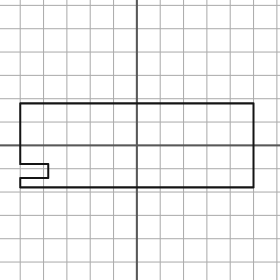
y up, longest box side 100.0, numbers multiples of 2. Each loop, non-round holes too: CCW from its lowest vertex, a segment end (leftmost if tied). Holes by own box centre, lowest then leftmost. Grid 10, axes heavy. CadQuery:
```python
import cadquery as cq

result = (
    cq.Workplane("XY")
    .moveTo(-50.0, -18.0)
    .lineTo(50.0, -18.0)
    .lineTo(50.0, 18.0)
    .lineTo(-50.0, 18.0)
    .lineTo(-50.0, -8.0)
    .lineTo(-38.0, -8.0)
    .lineTo(-38.0, -14.0)
    .lineTo(-50.0, -14.0)
    .close()
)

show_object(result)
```